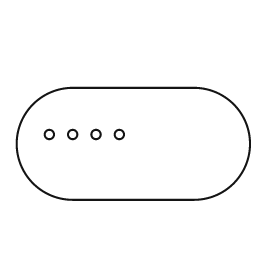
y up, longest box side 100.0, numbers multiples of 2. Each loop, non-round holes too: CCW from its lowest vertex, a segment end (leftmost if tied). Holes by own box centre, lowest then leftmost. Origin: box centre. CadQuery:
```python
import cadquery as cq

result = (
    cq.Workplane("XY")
    .moveTo(-26.0, -24.0)
    .lineTo(26.0, -24.0)
    .threePointArc((50.0, 0.0), (26.0, 24.0))
    .lineTo(-26.0, 24.0)
    .threePointArc((-50.0, 0.0), (-26.0, -24.0))
    .close()
    .moveTo(-36.0, 4.0)
    .circle(2.0)
    .moveTo(-26.0, 4.0)
    .circle(2.0)
    .moveTo(-16.0, 4.0)
    .circle(2.0)
    .moveTo(-6.0, 4.0)
    .circle(2.0)
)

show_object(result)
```